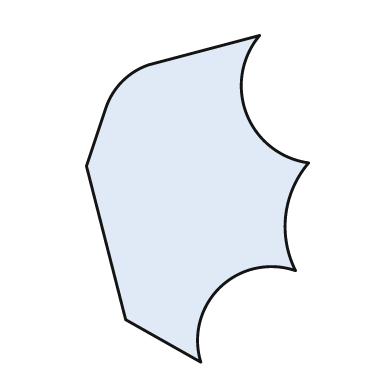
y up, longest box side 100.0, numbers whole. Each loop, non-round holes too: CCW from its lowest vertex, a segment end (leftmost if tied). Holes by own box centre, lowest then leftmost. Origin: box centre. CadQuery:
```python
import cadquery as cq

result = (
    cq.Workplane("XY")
    .moveTo(1.0, -50.0)
    .threePointArc((7.0, -27.0), (30.0, -22.0))
    .threePointArc((27.0, -5.0), (34.0, 11.0))
    .threePointArc((15.0, 26.0), (19.0, 50.0))
    .lineTo(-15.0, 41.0)
    .threePointArc((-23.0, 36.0), (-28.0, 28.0))
    .lineTo(-34.0, 10.0)
    .lineTo(-22.0, -37.0)
    .close()
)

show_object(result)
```